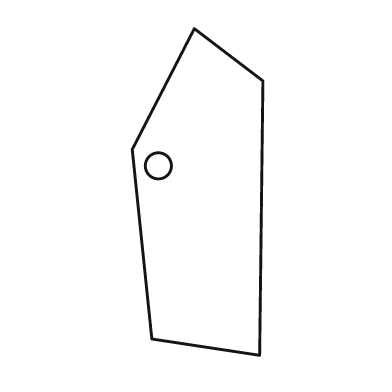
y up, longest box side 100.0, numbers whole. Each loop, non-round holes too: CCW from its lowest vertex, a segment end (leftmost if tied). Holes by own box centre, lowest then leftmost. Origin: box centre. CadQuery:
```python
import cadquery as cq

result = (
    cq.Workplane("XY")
    .moveTo(19.0, -50.0)
    .lineTo(20.0, 34.0)
    .lineTo(-1.0, 50.0)
    .lineTo(-20.0, 13.0)
    .lineTo(-14.0, -45.0)
    .close()
    .moveTo(-12.0, 8.0)
    .circle(4.0)
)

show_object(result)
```